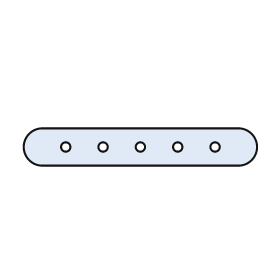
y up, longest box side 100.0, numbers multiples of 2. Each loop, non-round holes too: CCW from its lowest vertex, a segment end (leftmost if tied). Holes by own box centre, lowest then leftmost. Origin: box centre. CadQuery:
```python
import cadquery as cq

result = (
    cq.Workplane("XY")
    .moveTo(-42.0, -8.0)
    .lineTo(42.0, -8.0)
    .threePointArc((50.0, 0.0), (42.0, 8.0))
    .lineTo(-42.0, 8.0)
    .threePointArc((-50.0, 0.0), (-42.0, -8.0))
    .close()
    .moveTo(-32.0, 0.0)
    .circle(2.0)
    .moveTo(-16.0, 0.0)
    .circle(2.0)
    .moveTo(0.0, 0.0)
    .circle(2.0)
    .moveTo(16.0, 0.0)
    .circle(2.0)
    .moveTo(32.0, 0.0)
    .circle(2.0)
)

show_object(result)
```